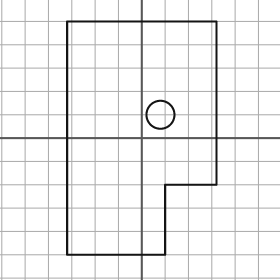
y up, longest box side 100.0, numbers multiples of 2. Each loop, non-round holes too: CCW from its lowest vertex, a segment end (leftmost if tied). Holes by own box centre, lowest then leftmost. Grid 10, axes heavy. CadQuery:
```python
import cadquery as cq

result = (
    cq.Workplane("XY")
    .moveTo(-32.0, -50.0)
    .lineTo(10.0, -50.0)
    .lineTo(10.0, -20.0)
    .lineTo(32.0, -20.0)
    .lineTo(32.0, 50.0)
    .lineTo(-32.0, 50.0)
    .close()
    .moveTo(8.0, 10.0)
    .circle(6.0)
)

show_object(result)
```